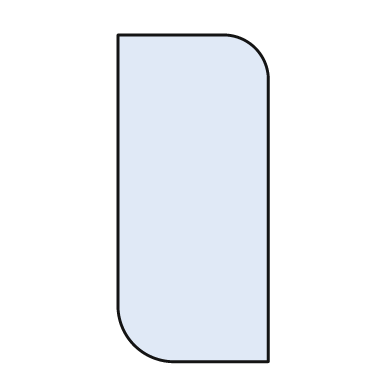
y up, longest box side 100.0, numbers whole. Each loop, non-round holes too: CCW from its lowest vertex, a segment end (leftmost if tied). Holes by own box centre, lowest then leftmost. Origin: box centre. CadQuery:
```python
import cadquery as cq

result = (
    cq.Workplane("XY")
    .moveTo(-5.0, -50.0)
    .lineTo(23.0, -50.0)
    .lineTo(23.0, 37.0)
    .threePointArc((19.0, 46.0), (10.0, 50.0))
    .lineTo(-23.0, 50.0)
    .lineTo(-23.0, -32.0)
    .threePointArc((-18.0, -45.0), (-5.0, -50.0))
    .close()
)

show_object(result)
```